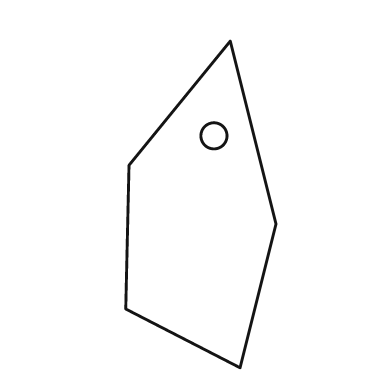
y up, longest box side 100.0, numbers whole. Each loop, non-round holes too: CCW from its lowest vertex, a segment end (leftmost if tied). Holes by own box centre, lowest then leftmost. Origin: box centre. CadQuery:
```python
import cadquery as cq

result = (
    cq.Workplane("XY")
    .moveTo(12.0, -50.0)
    .lineTo(23.0, -6.0)
    .lineTo(9.0, 50.0)
    .lineTo(-22.0, 12.0)
    .lineTo(-23.0, -32.0)
    .close()
    .moveTo(4.0, 21.0)
    .circle(4.0)
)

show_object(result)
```